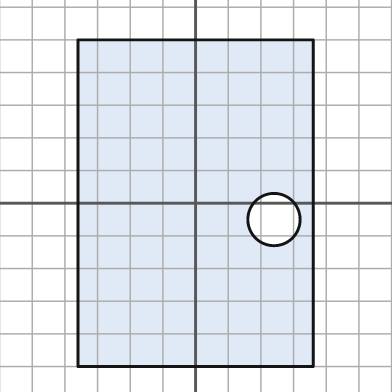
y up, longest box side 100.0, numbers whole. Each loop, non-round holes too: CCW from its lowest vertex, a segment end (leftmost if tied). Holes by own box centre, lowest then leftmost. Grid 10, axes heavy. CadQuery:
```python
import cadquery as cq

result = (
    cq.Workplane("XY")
    .moveTo(-36.0, -50.0)
    .lineTo(36.0, -50.0)
    .lineTo(36.0, 50.0)
    .lineTo(-36.0, 50.0)
    .close()
    .moveTo(24.0, -5.0)
    .circle(8.0)
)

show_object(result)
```